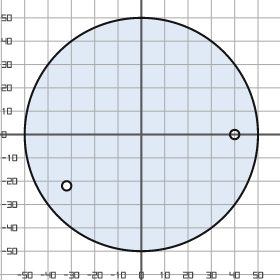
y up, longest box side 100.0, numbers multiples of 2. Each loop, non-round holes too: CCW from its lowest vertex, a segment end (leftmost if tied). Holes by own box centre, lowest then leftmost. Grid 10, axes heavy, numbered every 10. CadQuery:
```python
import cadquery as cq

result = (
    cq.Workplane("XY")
    .moveTo(0.0, 0.0)
    .circle(50.0)
    .moveTo(-32.0, -22.0)
    .circle(2.0)
    .moveTo(40.0, 0.0)
    .circle(2.0)
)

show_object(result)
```